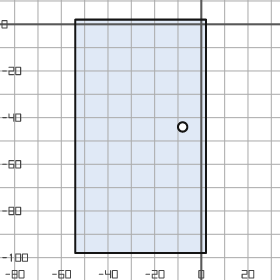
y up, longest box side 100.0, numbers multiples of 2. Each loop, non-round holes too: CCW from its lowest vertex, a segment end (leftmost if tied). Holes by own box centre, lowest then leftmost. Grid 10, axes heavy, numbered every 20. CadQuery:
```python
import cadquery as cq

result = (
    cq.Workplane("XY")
    .moveTo(-54.0, -98.0)
    .lineTo(2.0, -98.0)
    .lineTo(2.0, 2.0)
    .lineTo(-54.0, 2.0)
    .close()
    .moveTo(-8.0, -44.0)
    .circle(2.0)
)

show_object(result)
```